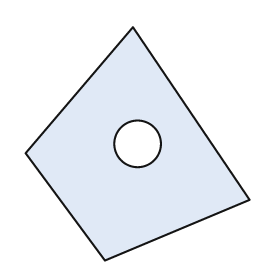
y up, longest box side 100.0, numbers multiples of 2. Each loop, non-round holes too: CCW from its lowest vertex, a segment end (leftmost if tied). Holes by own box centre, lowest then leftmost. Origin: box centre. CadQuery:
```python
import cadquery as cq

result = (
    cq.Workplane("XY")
    .moveTo(-14.0, -50.0)
    .lineTo(48.0, -24.0)
    .lineTo(-2.0, 50.0)
    .lineTo(-48.0, -4.0)
    .close()
    .moveTo(0.0, 0.0)
    .circle(10.0)
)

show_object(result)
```